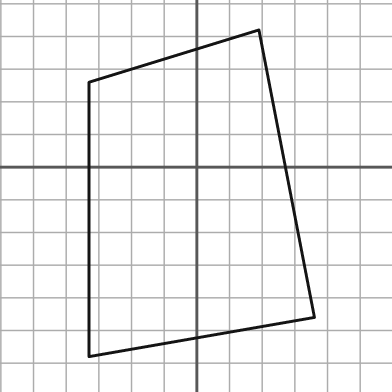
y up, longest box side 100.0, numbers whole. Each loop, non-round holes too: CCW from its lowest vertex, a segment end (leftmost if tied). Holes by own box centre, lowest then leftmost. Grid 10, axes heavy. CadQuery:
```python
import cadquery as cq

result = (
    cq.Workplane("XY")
    .moveTo(-33.0, -58.0)
    .lineTo(36.0, -46.0)
    .lineTo(19.0, 42.0)
    .lineTo(-33.0, 26.0)
    .close()
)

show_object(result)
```